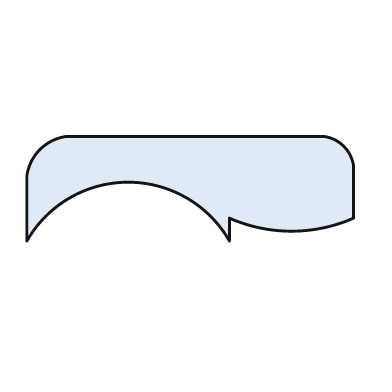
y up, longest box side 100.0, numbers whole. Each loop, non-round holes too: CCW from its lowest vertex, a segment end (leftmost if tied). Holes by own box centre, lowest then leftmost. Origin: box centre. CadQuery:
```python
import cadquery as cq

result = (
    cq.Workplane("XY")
    .moveTo(-50.0, -16.0)
    .threePointArc((-19.0, 2.0), (12.0, -16.0))
    .lineTo(12.0, -9.0)
    .threePointArc((31.0, -13.0), (50.0, -9.0))
    .lineTo(50.0, 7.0)
    .threePointArc((47.0, 13.0), (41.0, 16.0))
    .lineTo(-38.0, 16.0)
    .threePointArc((-46.0, 12.0), (-50.0, 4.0))
    .close()
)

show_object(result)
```